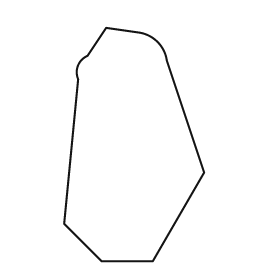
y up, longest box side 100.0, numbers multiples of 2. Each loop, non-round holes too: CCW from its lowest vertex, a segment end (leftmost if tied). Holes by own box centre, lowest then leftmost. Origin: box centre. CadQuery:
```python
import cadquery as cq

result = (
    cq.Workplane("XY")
    .moveTo(-14.0, -50.0)
    .lineTo(8.0, -50.0)
    .lineTo(30.0, -12.0)
    .lineTo(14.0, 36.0)
    .threePointArc((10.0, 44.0), (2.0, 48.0))
    .lineTo(-12.0, 50.0)
    .lineTo(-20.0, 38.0)
    .threePointArc((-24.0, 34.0), (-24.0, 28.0))
    .lineTo(-30.0, -34.0)
    .close()
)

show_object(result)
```